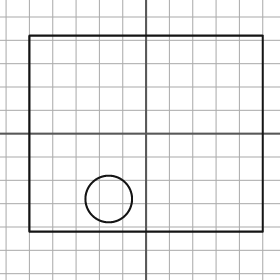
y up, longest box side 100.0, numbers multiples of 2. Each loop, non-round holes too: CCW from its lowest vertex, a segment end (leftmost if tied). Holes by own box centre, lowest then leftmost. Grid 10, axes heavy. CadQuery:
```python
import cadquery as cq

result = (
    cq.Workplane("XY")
    .moveTo(-50.0, -42.0)
    .lineTo(50.0, -42.0)
    .lineTo(50.0, 42.0)
    .lineTo(-50.0, 42.0)
    .close()
    .moveTo(-16.0, -28.0)
    .circle(10.0)
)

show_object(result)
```